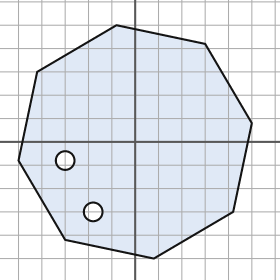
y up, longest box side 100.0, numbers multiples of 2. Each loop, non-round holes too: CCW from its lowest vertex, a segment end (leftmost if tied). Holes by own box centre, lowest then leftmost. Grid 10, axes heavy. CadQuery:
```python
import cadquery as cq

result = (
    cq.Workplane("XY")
    .moveTo(8.0, -50.0)
    .lineTo(42.0, -30.0)
    .lineTo(50.0, 8.0)
    .lineTo(30.0, 42.0)
    .lineTo(-8.0, 50.0)
    .lineTo(-42.0, 30.0)
    .lineTo(-50.0, -8.0)
    .lineTo(-30.0, -42.0)
    .close()
    .moveTo(-18.0, -30.0)
    .circle(4.0)
    .moveTo(-30.0, -8.0)
    .circle(4.0)
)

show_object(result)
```